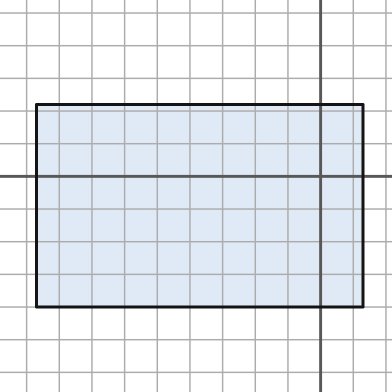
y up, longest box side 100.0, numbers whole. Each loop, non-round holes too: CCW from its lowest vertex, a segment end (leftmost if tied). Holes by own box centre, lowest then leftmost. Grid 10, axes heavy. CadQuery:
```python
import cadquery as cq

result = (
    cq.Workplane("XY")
    .moveTo(-87.0, -40.0)
    .lineTo(13.0, -40.0)
    .lineTo(13.0, 22.0)
    .lineTo(-87.0, 22.0)
    .close()
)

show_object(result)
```